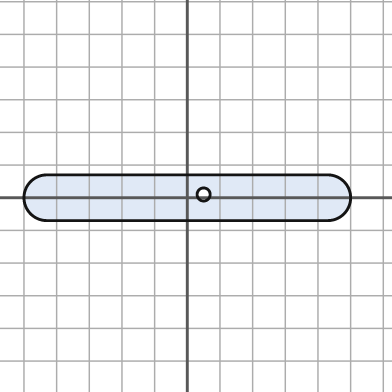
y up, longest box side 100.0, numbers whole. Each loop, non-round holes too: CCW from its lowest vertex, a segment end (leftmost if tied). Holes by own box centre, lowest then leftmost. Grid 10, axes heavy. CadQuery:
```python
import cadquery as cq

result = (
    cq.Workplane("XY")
    .moveTo(-43.0, -7.0)
    .lineTo(43.0, -7.0)
    .threePointArc((50.0, 0.0), (43.0, 7.0))
    .lineTo(-43.0, 7.0)
    .threePointArc((-50.0, 0.0), (-43.0, -7.0))
    .close()
    .moveTo(5.0, 1.0)
    .circle(2.0)
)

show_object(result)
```